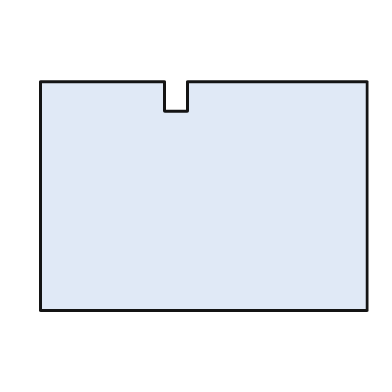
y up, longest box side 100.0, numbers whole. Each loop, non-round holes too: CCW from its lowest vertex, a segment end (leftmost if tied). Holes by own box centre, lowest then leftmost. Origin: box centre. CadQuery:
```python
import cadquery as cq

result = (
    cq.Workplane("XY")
    .moveTo(-50.0, -35.0)
    .lineTo(50.0, -35.0)
    .lineTo(50.0, 35.0)
    .lineTo(-5.0, 35.0)
    .lineTo(-5.0, 26.0)
    .lineTo(-12.0, 26.0)
    .lineTo(-12.0, 35.0)
    .lineTo(-50.0, 35.0)
    .close()
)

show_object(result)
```